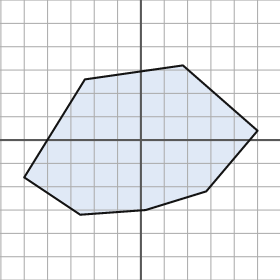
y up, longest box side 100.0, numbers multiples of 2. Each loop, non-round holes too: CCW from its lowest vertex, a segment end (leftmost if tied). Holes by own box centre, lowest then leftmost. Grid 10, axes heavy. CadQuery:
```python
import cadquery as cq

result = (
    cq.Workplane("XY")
    .moveTo(-26.0, -32.0)
    .lineTo(2.0, -30.0)
    .lineTo(28.0, -22.0)
    .lineTo(50.0, 4.0)
    .lineTo(18.0, 32.0)
    .lineTo(-24.0, 26.0)
    .lineTo(-50.0, -16.0)
    .close()
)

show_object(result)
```